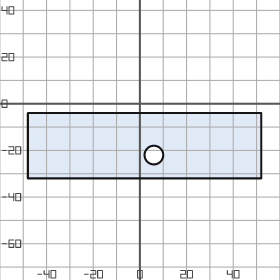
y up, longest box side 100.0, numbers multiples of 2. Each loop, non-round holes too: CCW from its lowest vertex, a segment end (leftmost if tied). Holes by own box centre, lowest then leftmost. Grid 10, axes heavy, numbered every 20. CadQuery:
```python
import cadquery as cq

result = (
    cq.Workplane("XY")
    .moveTo(-48.0, -32.0)
    .lineTo(52.0, -32.0)
    .lineTo(52.0, -4.0)
    .lineTo(-48.0, -4.0)
    .close()
    .moveTo(6.0, -22.0)
    .circle(4.0)
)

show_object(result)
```